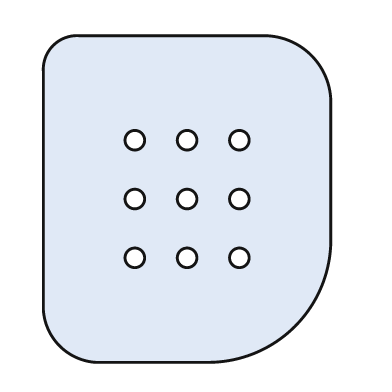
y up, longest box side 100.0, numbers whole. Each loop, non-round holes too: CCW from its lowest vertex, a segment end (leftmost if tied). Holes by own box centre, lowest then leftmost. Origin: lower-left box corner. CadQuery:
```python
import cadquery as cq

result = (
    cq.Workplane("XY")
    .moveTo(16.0, 0.0)
    .lineTo(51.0, 0.0)
    .threePointArc((77.0, 11.0), (88.0, 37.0))
    .lineTo(88.0, 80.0)
    .threePointArc((82.0, 94.0), (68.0, 100.0))
    .lineTo(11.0, 100.0)
    .threePointArc((3.0, 97.0), (0.0, 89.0))
    .lineTo(0.0, 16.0)
    .threePointArc((5.0, 5.0), (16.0, 0.0))
    .close()
    .moveTo(28.0, 32.0)
    .circle(3.0)
    .moveTo(44.0, 32.0)
    .circle(3.0)
    .moveTo(60.0, 32.0)
    .circle(3.0)
    .moveTo(28.0, 50.0)
    .circle(3.0)
    .moveTo(44.0, 50.0)
    .circle(3.0)
    .moveTo(60.0, 50.0)
    .circle(3.0)
    .moveTo(28.0, 68.0)
    .circle(3.0)
    .moveTo(44.0, 68.0)
    .circle(3.0)
    .moveTo(60.0, 68.0)
    .circle(3.0)
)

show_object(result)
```